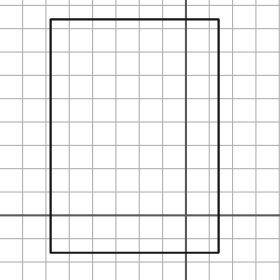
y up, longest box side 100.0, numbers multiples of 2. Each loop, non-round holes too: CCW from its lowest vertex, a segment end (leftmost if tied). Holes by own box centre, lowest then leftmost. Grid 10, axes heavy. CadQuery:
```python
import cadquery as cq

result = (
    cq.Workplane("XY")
    .moveTo(-58.0, -16.0)
    .lineTo(14.0, -16.0)
    .lineTo(14.0, 84.0)
    .lineTo(-58.0, 84.0)
    .close()
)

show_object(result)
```